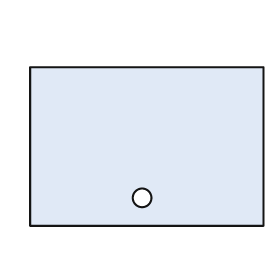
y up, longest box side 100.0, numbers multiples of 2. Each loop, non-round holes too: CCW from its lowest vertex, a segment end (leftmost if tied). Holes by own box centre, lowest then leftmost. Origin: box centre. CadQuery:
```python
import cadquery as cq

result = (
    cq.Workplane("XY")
    .moveTo(-50.0, -34.0)
    .lineTo(50.0, -34.0)
    .lineTo(50.0, 34.0)
    .lineTo(-50.0, 34.0)
    .close()
    .moveTo(-2.0, -22.0)
    .circle(4.0)
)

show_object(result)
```